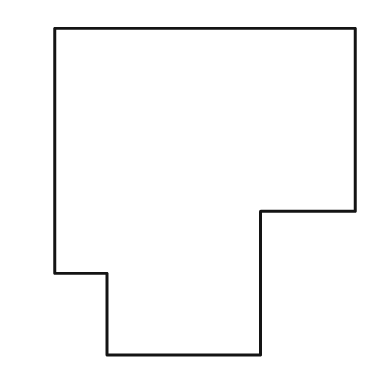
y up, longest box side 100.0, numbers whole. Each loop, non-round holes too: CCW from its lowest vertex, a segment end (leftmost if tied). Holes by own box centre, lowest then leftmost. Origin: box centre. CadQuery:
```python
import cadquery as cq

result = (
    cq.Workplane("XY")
    .moveTo(-30.0, -50.0)
    .lineTo(17.0, -50.0)
    .lineTo(17.0, -6.0)
    .lineTo(46.0, -6.0)
    .lineTo(46.0, 50.0)
    .lineTo(-46.0, 50.0)
    .lineTo(-46.0, -25.0)
    .lineTo(-30.0, -25.0)
    .close()
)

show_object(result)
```